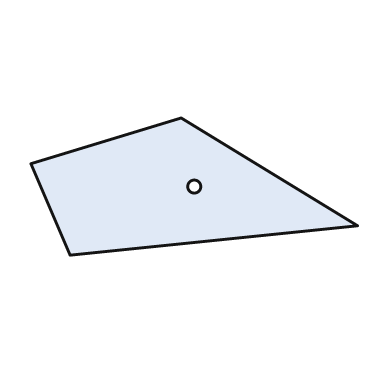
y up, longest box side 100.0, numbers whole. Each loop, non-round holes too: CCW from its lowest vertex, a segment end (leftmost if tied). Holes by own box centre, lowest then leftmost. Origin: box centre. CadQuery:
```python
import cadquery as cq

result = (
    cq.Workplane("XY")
    .moveTo(-38.0, -21.0)
    .lineTo(50.0, -12.0)
    .lineTo(-4.0, 21.0)
    .lineTo(-50.0, 7.0)
    .close()
    .moveTo(0.0, 0.0)
    .circle(2.0)
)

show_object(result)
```